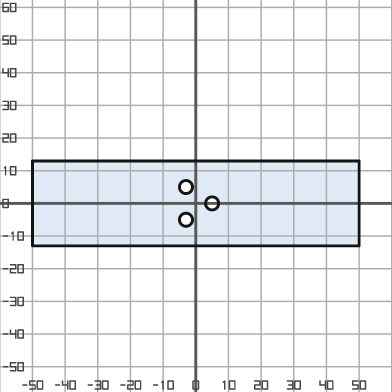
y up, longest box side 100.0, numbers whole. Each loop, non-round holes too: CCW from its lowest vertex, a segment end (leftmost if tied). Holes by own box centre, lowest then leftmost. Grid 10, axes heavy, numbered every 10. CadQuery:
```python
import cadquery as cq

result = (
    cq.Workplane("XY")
    .moveTo(-50.0, -13.0)
    .lineTo(50.0, -13.0)
    .lineTo(50.0, 13.0)
    .lineTo(-50.0, 13.0)
    .close()
    .moveTo(-3.0, -5.0)
    .circle(2.0)
    .moveTo(5.0, 0.0)
    .circle(2.0)
    .moveTo(-3.0, 5.0)
    .circle(2.0)
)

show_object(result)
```